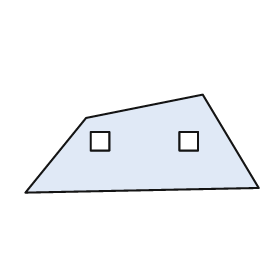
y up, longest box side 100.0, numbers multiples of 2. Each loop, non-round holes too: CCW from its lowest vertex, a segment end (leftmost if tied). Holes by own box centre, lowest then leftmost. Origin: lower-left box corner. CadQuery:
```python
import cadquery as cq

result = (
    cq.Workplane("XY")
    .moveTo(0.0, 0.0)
    .lineTo(100.0, 2.0)
    .lineTo(76.0, 42.0)
    .lineTo(26.0, 32.0)
    .close()
    .moveTo(28.0, 18.0)
    .lineTo(36.0, 18.0)
    .lineTo(36.0, 26.0)
    .lineTo(28.0, 26.0)
    .close()
    .moveTo(66.0, 18.0)
    .lineTo(74.0, 18.0)
    .lineTo(74.0, 26.0)
    .lineTo(66.0, 26.0)
    .close()
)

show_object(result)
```